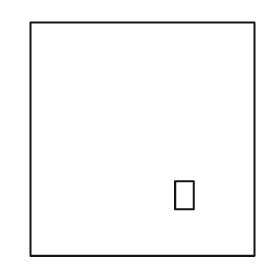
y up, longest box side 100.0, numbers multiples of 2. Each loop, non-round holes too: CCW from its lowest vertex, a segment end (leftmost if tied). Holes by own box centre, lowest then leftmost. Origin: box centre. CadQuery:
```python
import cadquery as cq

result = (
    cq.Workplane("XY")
    .moveTo(-48.0, -50.0)
    .lineTo(48.0, -50.0)
    .lineTo(48.0, 50.0)
    .lineTo(-48.0, 50.0)
    .close()
    .moveTo(14.0, -30.0)
    .lineTo(22.0, -30.0)
    .lineTo(22.0, -18.0)
    .lineTo(14.0, -18.0)
    .close()
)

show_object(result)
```